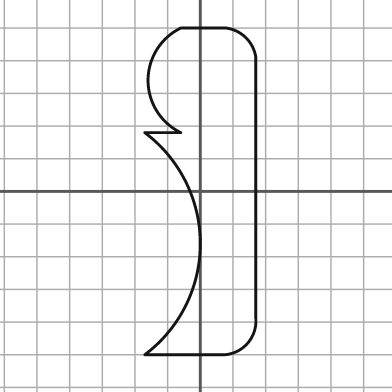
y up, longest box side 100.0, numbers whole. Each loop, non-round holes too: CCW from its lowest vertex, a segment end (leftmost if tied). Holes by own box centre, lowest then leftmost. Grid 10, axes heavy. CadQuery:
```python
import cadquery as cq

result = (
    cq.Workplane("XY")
    .moveTo(-17.0, -50.0)
    .lineTo(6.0, -50.0)
    .threePointArc((14.0, -47.0), (17.0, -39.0))
    .lineTo(17.0, 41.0)
    .threePointArc((14.0, 47.0), (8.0, 50.0))
    .lineTo(-6.0, 50.0)
    .threePointArc((-16.0, 34.0), (-6.0, 18.0))
    .lineTo(-17.0, 18.0)
    .threePointArc((0.0, -16.0), (-17.0, -50.0))
    .close()
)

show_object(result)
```